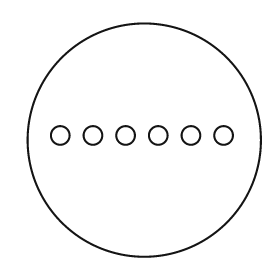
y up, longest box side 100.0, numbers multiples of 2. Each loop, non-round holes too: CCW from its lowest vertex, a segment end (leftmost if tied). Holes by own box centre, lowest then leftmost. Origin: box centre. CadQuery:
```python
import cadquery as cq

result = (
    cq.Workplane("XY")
    .moveTo(0.0, 0.0)
    .circle(50.0)
    .moveTo(-36.0, 2.0)
    .circle(4.0)
    .moveTo(-22.0, 2.0)
    .circle(4.0)
    .moveTo(-8.0, 2.0)
    .circle(4.0)
    .moveTo(6.0, 2.0)
    .circle(4.0)
    .moveTo(20.0, 2.0)
    .circle(4.0)
    .moveTo(34.0, 2.0)
    .circle(4.0)
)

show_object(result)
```